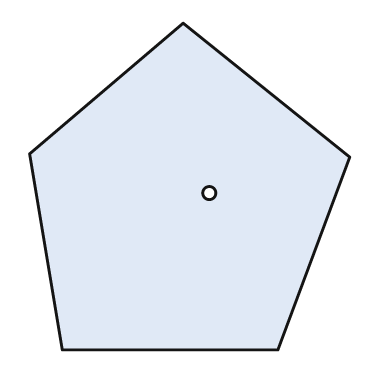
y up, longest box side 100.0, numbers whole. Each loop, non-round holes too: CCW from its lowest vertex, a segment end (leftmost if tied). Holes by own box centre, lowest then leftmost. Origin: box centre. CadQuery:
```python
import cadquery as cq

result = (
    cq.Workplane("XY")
    .moveTo(-39.0, -50.0)
    .lineTo(27.0, -50.0)
    .lineTo(49.0, 9.0)
    .lineTo(-2.0, 50.0)
    .lineTo(-49.0, 10.0)
    .close()
    .moveTo(6.0, -2.0)
    .circle(2.0)
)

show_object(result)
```